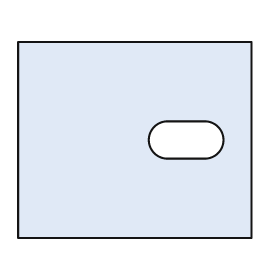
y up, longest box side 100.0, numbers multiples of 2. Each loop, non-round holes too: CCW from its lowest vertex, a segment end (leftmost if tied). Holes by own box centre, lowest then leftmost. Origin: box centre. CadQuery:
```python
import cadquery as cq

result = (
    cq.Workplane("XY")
    .moveTo(-50.0, -42.0)
    .lineTo(50.0, -42.0)
    .lineTo(50.0, 42.0)
    .lineTo(-50.0, 42.0)
    .close()
    .moveTo(14.0, -8.0)
    .lineTo(30.0, -8.0)
    .threePointArc((38.0, 0.0), (30.0, 8.0))
    .lineTo(14.0, 8.0)
    .threePointArc((6.0, 0.0), (14.0, -8.0))
    .close()
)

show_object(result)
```